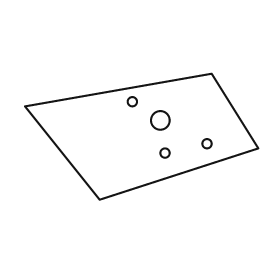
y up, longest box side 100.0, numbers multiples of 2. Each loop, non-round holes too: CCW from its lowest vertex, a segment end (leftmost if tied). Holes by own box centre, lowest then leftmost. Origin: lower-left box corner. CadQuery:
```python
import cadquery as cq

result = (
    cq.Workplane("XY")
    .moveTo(32.0, 0.0)
    .lineTo(100.0, 22.0)
    .lineTo(80.0, 54.0)
    .lineTo(0.0, 40.0)
    .close()
    .moveTo(60.0, 20.0)
    .circle(2.0)
    .moveTo(78.0, 24.0)
    .circle(2.0)
    .moveTo(58.0, 34.0)
    .circle(4.0)
    .moveTo(46.0, 42.0)
    .circle(2.0)
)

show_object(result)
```